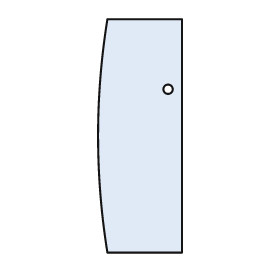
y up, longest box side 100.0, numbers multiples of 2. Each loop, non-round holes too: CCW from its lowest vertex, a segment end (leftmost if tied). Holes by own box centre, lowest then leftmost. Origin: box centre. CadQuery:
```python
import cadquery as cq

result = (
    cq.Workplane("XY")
    .moveTo(-14.0, -50.0)
    .lineTo(18.0, -50.0)
    .lineTo(18.0, 50.0)
    .lineTo(-14.0, 50.0)
    .threePointArc((-18.0, 0.0), (-14.0, -50.0))
    .close()
    .moveTo(12.0, 20.0)
    .circle(2.0)
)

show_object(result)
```